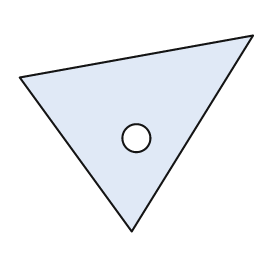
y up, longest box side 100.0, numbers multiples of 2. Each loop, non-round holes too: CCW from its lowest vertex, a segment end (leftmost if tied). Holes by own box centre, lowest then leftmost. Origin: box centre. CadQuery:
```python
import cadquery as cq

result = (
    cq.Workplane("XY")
    .moveTo(-2.0, -42.0)
    .lineTo(50.0, 42.0)
    .lineTo(-50.0, 24.0)
    .close()
    .moveTo(0.0, -2.0)
    .circle(6.0)
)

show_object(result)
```